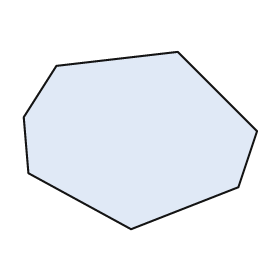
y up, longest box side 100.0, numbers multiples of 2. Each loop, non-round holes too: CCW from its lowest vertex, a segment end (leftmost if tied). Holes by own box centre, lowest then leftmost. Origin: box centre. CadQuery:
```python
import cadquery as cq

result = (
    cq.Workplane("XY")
    .moveTo(-4.0, -38.0)
    .lineTo(42.0, -20.0)
    .lineTo(50.0, 4.0)
    .lineTo(16.0, 38.0)
    .lineTo(-36.0, 32.0)
    .lineTo(-50.0, 10.0)
    .lineTo(-48.0, -14.0)
    .close()
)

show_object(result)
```